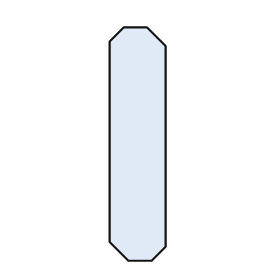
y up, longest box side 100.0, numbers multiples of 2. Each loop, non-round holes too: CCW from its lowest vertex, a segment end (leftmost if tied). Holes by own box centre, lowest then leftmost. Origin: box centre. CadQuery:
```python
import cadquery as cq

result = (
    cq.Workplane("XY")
    .moveTo(-4.0, -50.0)
    .lineTo(6.0, -50.0)
    .lineTo(12.0, -44.0)
    .lineTo(12.0, 42.0)
    .lineTo(4.0, 50.0)
    .lineTo(-6.0, 50.0)
    .lineTo(-12.0, 44.0)
    .lineTo(-12.0, -42.0)
    .close()
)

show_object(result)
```